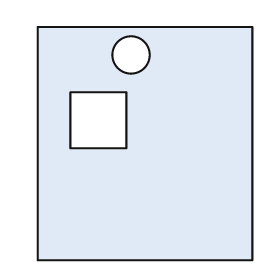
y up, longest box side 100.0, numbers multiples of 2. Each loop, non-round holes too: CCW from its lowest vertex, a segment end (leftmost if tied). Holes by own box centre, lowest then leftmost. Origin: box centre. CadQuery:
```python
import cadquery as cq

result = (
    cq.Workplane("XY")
    .moveTo(-46.0, -50.0)
    .lineTo(46.0, -50.0)
    .lineTo(46.0, 50.0)
    .lineTo(-46.0, 50.0)
    .close()
    .moveTo(-32.0, -2.0)
    .lineTo(-8.0, -2.0)
    .lineTo(-8.0, 22.0)
    .lineTo(-32.0, 22.0)
    .close()
    .moveTo(-6.0, 38.0)
    .circle(8.0)
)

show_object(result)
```